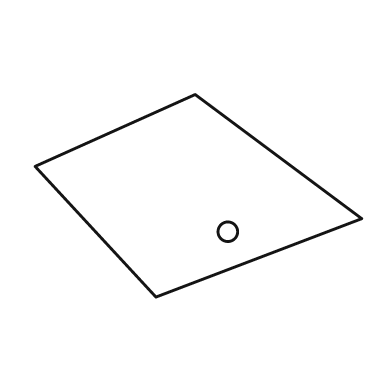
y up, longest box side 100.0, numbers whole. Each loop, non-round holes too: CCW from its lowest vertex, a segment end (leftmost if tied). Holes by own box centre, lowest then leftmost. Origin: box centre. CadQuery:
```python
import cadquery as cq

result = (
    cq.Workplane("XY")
    .moveTo(-13.0, -31.0)
    .lineTo(50.0, -7.0)
    .lineTo(-1.0, 31.0)
    .lineTo(-50.0, 9.0)
    .close()
    .moveTo(9.0, -11.0)
    .circle(3.0)
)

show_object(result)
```